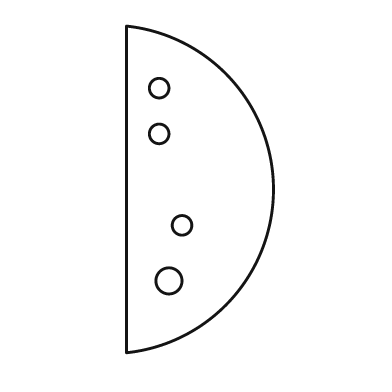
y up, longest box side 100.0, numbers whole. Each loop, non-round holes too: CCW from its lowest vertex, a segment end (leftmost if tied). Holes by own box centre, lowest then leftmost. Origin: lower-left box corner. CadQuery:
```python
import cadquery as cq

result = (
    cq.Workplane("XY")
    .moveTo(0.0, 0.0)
    .threePointArc((45.0, 50.0), (0.0, 100.0))
    .close()
    .moveTo(13.0, 22.0)
    .circle(4.0)
    .moveTo(17.0, 39.0)
    .circle(3.0)
    .moveTo(10.0, 67.0)
    .circle(3.0)
    .moveTo(10.0, 81.0)
    .circle(3.0)
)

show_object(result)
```